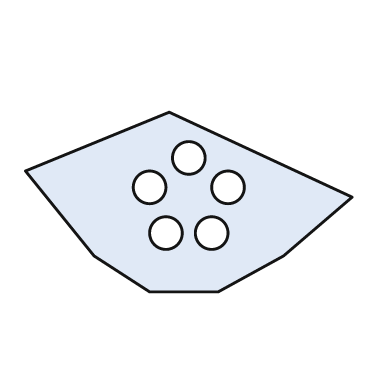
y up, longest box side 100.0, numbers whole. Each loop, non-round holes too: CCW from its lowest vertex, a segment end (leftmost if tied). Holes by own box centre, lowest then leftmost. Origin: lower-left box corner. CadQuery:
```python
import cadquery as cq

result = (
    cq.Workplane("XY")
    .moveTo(38.0, 0.0)
    .lineTo(59.0, 0.0)
    .lineTo(79.0, 11.0)
    .lineTo(100.0, 29.0)
    .lineTo(44.0, 55.0)
    .lineTo(0.0, 37.0)
    .lineTo(21.0, 11.0)
    .close()
    .moveTo(43.0, 18.0)
    .circle(5.0)
    .moveTo(57.0, 18.0)
    .circle(5.0)
    .moveTo(38.0, 32.0)
    .circle(5.0)
    .moveTo(62.0, 32.0)
    .circle(5.0)
    .moveTo(50.0, 41.0)
    .circle(5.0)
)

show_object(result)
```